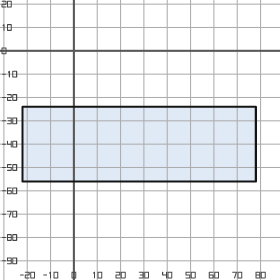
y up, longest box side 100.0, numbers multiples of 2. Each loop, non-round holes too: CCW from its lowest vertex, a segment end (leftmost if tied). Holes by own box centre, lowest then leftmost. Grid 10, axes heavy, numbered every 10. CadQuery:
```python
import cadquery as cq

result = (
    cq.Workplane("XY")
    .moveTo(-22.0, -56.0)
    .lineTo(78.0, -56.0)
    .lineTo(78.0, -24.0)
    .lineTo(-22.0, -24.0)
    .close()
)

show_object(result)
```